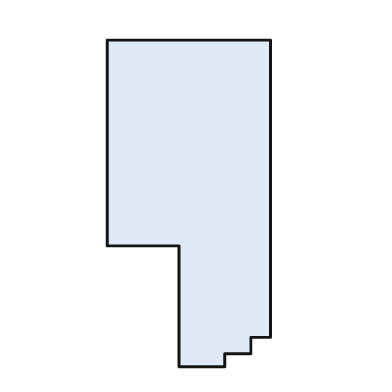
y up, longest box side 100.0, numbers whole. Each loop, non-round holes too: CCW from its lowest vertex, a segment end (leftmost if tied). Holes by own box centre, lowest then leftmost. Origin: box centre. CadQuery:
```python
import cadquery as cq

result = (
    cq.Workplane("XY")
    .moveTo(-3.0, -50.0)
    .lineTo(11.0, -50.0)
    .lineTo(11.0, -46.0)
    .lineTo(19.0, -46.0)
    .lineTo(19.0, -41.0)
    .lineTo(25.0, -41.0)
    .lineTo(25.0, 50.0)
    .lineTo(-25.0, 50.0)
    .lineTo(-25.0, -13.0)
    .lineTo(-3.0, -13.0)
    .close()
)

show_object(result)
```